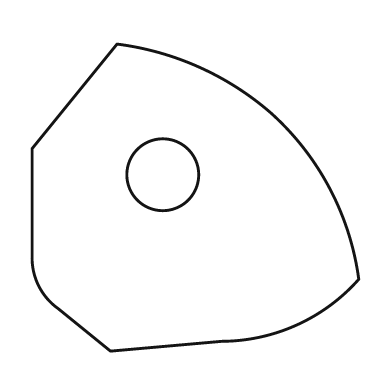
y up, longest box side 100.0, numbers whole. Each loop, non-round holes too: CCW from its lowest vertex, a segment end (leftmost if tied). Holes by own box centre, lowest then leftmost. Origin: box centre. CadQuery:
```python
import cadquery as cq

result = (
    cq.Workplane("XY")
    .moveTo(-26.0, -47.0)
    .lineTo(8.0, -44.0)
    .threePointArc((31.0, -39.0), (50.0, -25.0))
    .threePointArc((41.0, 3.0), (23.0, 26.0))
    .threePointArc((1.0, 40.0), (-24.0, 47.0))
    .lineTo(-50.0, 15.0)
    .lineTo(-50.0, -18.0)
    .threePointArc((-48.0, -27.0), (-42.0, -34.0))
    .close()
    .moveTo(-10.0, 7.0)
    .circle(11.0)
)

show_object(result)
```